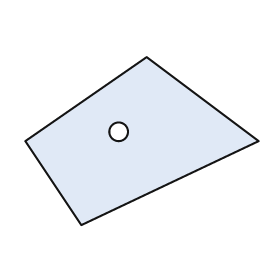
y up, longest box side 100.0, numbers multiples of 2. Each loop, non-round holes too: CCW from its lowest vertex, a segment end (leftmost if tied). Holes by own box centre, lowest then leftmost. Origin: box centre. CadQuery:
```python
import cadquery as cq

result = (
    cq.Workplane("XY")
    .moveTo(-26.0, -36.0)
    .lineTo(50.0, 0.0)
    .lineTo(2.0, 36.0)
    .lineTo(-50.0, 0.0)
    .close()
    .moveTo(-10.0, 4.0)
    .circle(4.0)
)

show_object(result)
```